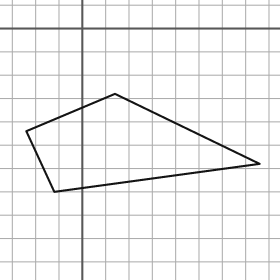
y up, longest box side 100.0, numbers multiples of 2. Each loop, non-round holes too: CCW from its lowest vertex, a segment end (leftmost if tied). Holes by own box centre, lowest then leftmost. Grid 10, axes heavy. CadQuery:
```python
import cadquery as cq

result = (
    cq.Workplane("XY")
    .moveTo(-12.0, -70.0)
    .lineTo(76.0, -58.0)
    .lineTo(14.0, -28.0)
    .lineTo(-24.0, -44.0)
    .close()
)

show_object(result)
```